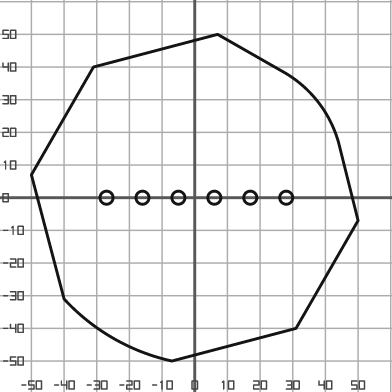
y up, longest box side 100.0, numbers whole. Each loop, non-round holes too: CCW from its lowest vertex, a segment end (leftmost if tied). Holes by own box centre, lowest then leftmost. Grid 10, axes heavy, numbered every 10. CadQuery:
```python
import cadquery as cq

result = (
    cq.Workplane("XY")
    .moveTo(-7.0, -50.0)
    .lineTo(31.0, -40.0)
    .lineTo(50.0, -7.0)
    .lineTo(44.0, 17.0)
    .threePointArc((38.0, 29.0), (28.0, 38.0))
    .lineTo(7.0, 50.0)
    .lineTo(-31.0, 40.0)
    .lineTo(-50.0, 7.0)
    .lineTo(-40.0, -31.0)
    .threePointArc((-25.0, -43.0), (-7.0, -50.0))
    .close()
    .moveTo(-27.0, 0.0)
    .circle(2.0)
    .moveTo(-16.0, 0.0)
    .circle(2.0)
    .moveTo(-5.0, 0.0)
    .circle(2.0)
    .moveTo(6.0, 0.0)
    .circle(2.0)
    .moveTo(17.0, 0.0)
    .circle(2.0)
    .moveTo(28.0, 0.0)
    .circle(2.0)
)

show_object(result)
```